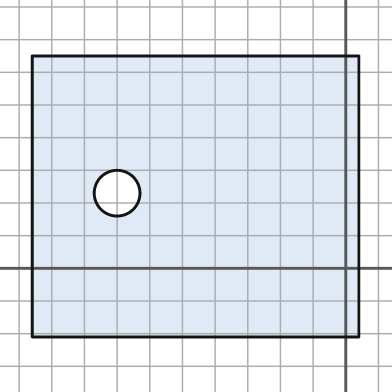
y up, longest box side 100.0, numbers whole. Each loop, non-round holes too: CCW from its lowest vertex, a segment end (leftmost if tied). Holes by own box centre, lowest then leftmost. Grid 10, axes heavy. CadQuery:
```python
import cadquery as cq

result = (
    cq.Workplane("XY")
    .moveTo(-96.0, -21.0)
    .lineTo(4.0, -21.0)
    .lineTo(4.0, 65.0)
    .lineTo(-96.0, 65.0)
    .close()
    .moveTo(-70.0, 23.0)
    .circle(7.0)
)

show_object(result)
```